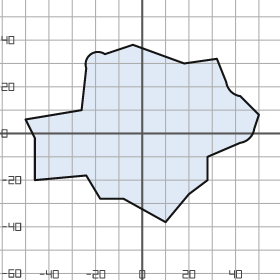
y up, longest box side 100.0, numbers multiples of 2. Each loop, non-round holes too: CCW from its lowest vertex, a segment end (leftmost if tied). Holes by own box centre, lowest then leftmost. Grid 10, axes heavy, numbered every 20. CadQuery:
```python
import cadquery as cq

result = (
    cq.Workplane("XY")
    .moveTo(10.0, -38.0)
    .lineTo(20.0, -26.0)
    .lineTo(28.0, -20.0)
    .lineTo(28.0, -10.0)
    .lineTo(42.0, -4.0)
    .threePointArc((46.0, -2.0), (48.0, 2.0))
    .lineTo(50.0, 8.0)
    .lineTo(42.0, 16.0)
    .threePointArc((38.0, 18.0), (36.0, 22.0))
    .lineTo(32.0, 32.0)
    .lineTo(18.0, 30.0)
    .lineTo(-4.0, 38.0)
    .lineTo(-16.0, 34.0)
    .threePointArc((-22.0, 34.0), (-24.0, 28.0))
    .lineTo(-26.0, 10.0)
    .lineTo(-50.0, 6.0)
    .lineTo(-46.0, -2.0)
    .lineTo(-46.0, -20.0)
    .lineTo(-24.0, -18.0)
    .lineTo(-18.0, -28.0)
    .lineTo(-8.0, -28.0)
    .close()
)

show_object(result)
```